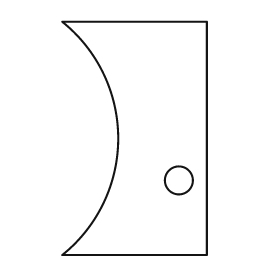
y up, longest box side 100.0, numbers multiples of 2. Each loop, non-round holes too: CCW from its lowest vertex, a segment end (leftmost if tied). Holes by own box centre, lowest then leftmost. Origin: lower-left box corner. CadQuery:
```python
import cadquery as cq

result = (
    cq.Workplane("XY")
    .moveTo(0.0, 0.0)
    .lineTo(62.0, 0.0)
    .lineTo(62.0, 100.0)
    .lineTo(0.0, 100.0)
    .threePointArc((24.0, 50.0), (0.0, 0.0))
    .close()
    .moveTo(50.0, 32.0)
    .circle(6.0)
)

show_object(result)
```